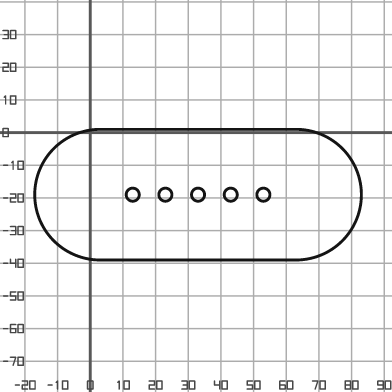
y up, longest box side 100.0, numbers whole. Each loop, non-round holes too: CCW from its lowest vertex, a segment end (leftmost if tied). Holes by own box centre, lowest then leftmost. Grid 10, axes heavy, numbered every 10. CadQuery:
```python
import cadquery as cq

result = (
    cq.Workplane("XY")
    .moveTo(3.0, -39.0)
    .lineTo(63.0, -39.0)
    .threePointArc((83.0, -19.0), (63.0, 1.0))
    .lineTo(3.0, 1.0)
    .threePointArc((-17.0, -19.0), (3.0, -39.0))
    .close()
    .moveTo(13.0, -19.0)
    .circle(2.0)
    .moveTo(23.0, -19.0)
    .circle(2.0)
    .moveTo(33.0, -19.0)
    .circle(2.0)
    .moveTo(43.0, -19.0)
    .circle(2.0)
    .moveTo(53.0, -19.0)
    .circle(2.0)
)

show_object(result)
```